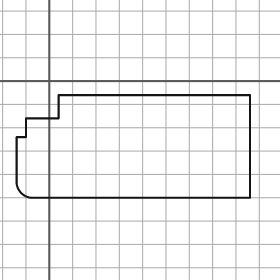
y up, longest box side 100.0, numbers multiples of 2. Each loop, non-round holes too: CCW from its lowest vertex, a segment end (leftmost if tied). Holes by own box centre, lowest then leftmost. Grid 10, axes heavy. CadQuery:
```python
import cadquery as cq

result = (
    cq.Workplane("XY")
    .moveTo(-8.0, -50.0)
    .lineTo(86.0, -50.0)
    .lineTo(86.0, -6.0)
    .lineTo(4.0, -6.0)
    .lineTo(4.0, -16.0)
    .lineTo(-10.0, -16.0)
    .lineTo(-10.0, -24.0)
    .lineTo(-14.0, -24.0)
    .lineTo(-14.0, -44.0)
    .threePointArc((-12.0, -48.0), (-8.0, -50.0))
    .close()
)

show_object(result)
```